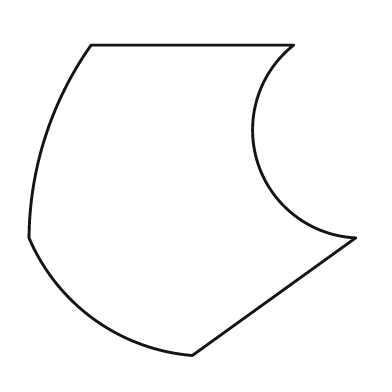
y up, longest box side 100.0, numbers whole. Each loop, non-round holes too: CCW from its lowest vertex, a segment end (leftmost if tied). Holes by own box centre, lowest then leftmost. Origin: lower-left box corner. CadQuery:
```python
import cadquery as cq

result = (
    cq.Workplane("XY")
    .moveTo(50.0, 0.0)
    .lineTo(100.0, 36.0)
    .threePointArc((70.0, 59.0), (81.0, 95.0))
    .lineTo(19.0, 95.0)
    .threePointArc((5.0, 67.0), (0.0, 36.0))
    .threePointArc((20.0, 11.0), (50.0, 0.0))
    .close()
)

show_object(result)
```